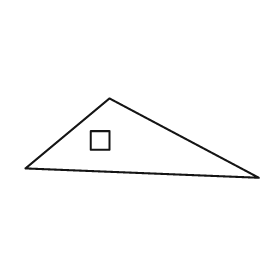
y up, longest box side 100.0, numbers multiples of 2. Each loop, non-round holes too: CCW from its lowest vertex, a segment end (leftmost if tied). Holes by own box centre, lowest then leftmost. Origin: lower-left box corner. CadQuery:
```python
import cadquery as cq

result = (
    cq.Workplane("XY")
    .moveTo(100.0, 0.0)
    .lineTo(36.0, 34.0)
    .lineTo(0.0, 4.0)
    .close()
    .moveTo(28.0, 12.0)
    .lineTo(36.0, 12.0)
    .lineTo(36.0, 20.0)
    .lineTo(28.0, 20.0)
    .close()
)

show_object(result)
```